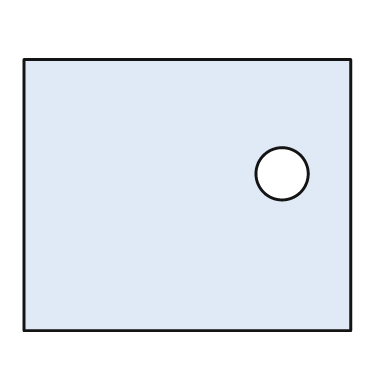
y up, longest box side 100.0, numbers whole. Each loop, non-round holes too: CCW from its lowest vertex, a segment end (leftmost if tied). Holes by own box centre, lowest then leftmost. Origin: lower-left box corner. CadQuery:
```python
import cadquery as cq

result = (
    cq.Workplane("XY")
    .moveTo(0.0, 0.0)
    .lineTo(100.0, 0.0)
    .lineTo(100.0, 83.0)
    .lineTo(0.0, 83.0)
    .close()
    .moveTo(79.0, 48.0)
    .circle(8.0)
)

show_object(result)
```